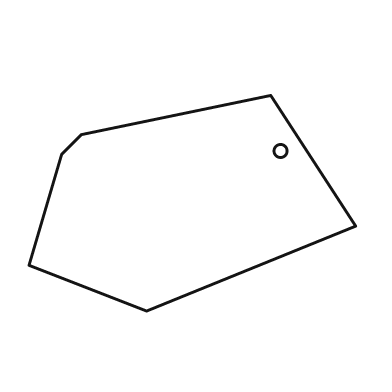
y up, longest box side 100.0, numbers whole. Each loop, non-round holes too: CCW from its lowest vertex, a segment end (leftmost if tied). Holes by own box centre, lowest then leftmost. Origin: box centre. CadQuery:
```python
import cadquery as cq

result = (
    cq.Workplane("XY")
    .moveTo(-14.0, -33.0)
    .lineTo(50.0, -7.0)
    .lineTo(24.0, 33.0)
    .lineTo(-34.0, 21.0)
    .lineTo(-40.0, 15.0)
    .lineTo(-50.0, -19.0)
    .close()
    .moveTo(27.0, 16.0)
    .circle(2.0)
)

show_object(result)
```